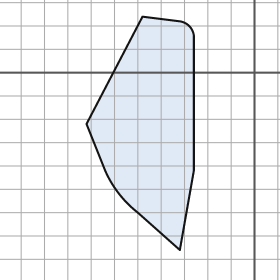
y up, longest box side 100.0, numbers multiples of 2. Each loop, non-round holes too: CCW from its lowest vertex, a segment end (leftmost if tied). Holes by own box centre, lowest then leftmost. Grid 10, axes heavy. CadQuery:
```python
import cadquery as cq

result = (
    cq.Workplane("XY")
    .moveTo(-32.0, -76.0)
    .lineTo(-26.0, -42.0)
    .lineTo(-26.0, 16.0)
    .threePointArc((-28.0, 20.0), (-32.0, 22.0))
    .lineTo(-48.0, 24.0)
    .lineTo(-72.0, -22.0)
    .lineTo(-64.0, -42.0)
    .threePointArc((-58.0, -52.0), (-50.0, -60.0))
    .close()
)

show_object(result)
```